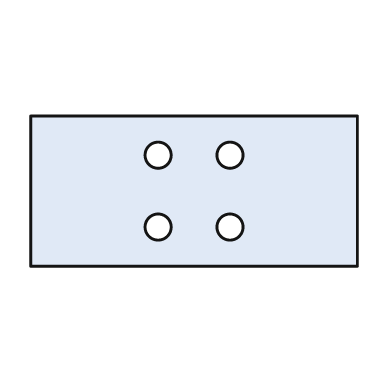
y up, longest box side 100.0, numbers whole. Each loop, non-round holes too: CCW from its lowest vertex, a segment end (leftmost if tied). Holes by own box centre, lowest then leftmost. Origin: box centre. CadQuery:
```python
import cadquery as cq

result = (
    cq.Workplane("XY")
    .moveTo(-50.0, -23.0)
    .lineTo(50.0, -23.0)
    .lineTo(50.0, 23.0)
    .lineTo(-50.0, 23.0)
    .close()
    .moveTo(-11.0, -11.0)
    .circle(4.0)
    .moveTo(11.0, -11.0)
    .circle(4.0)
    .moveTo(-11.0, 11.0)
    .circle(4.0)
    .moveTo(11.0, 11.0)
    .circle(4.0)
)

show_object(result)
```